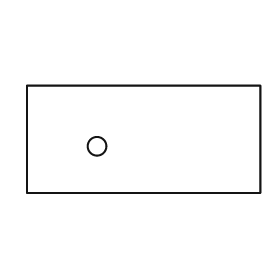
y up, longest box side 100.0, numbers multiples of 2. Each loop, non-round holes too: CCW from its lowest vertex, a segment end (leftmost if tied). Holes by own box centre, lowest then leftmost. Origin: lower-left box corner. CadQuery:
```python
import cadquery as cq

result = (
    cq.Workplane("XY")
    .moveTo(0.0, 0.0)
    .lineTo(100.0, 0.0)
    .lineTo(100.0, 46.0)
    .lineTo(0.0, 46.0)
    .close()
    .moveTo(30.0, 20.0)
    .circle(4.0)
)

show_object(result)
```